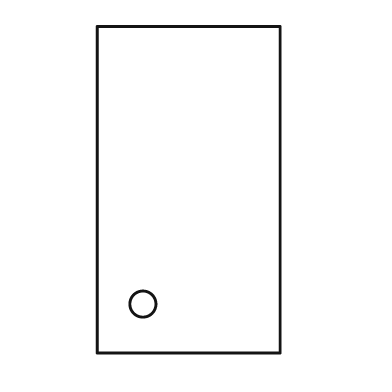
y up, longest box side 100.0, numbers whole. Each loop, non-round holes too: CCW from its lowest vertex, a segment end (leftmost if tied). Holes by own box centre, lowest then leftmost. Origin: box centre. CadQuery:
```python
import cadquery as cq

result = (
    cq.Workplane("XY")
    .moveTo(-28.0, -50.0)
    .lineTo(28.0, -50.0)
    .lineTo(28.0, 50.0)
    .lineTo(-28.0, 50.0)
    .close()
    .moveTo(-14.0, -35.0)
    .circle(4.0)
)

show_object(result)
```